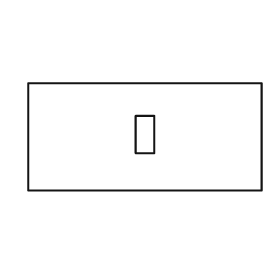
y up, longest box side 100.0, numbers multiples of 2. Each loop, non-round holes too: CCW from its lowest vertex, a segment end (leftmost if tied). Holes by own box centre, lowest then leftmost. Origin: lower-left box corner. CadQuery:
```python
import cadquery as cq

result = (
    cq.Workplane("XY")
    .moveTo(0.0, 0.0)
    .lineTo(100.0, 0.0)
    .lineTo(100.0, 46.0)
    .lineTo(0.0, 46.0)
    .close()
    .moveTo(46.0, 16.0)
    .lineTo(54.0, 16.0)
    .lineTo(54.0, 32.0)
    .lineTo(46.0, 32.0)
    .close()
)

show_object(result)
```